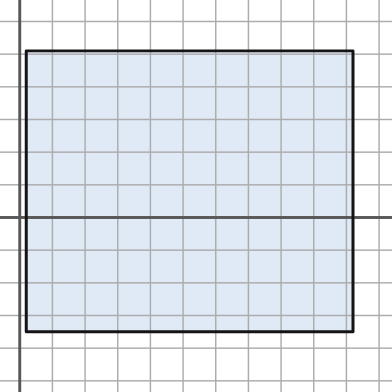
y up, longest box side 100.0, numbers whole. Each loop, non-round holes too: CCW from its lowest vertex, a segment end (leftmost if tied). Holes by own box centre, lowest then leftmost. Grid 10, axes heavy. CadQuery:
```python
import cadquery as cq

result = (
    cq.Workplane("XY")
    .moveTo(2.0, -35.0)
    .lineTo(102.0, -35.0)
    .lineTo(102.0, 51.0)
    .lineTo(2.0, 51.0)
    .close()
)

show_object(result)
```